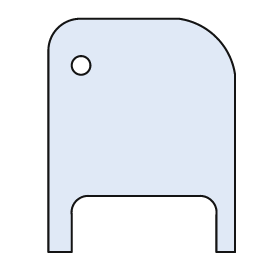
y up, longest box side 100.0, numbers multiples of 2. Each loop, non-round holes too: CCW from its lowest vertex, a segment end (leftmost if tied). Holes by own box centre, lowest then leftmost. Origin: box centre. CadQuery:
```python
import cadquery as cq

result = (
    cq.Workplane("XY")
    .moveTo(-40.0, -50.0)
    .lineTo(-30.0, -50.0)
    .lineTo(-30.0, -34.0)
    .threePointArc((-28.0, -28.0), (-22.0, -26.0))
    .lineTo(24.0, -26.0)
    .threePointArc((30.0, -28.0), (32.0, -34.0))
    .lineTo(32.0, -50.0)
    .lineTo(40.0, -50.0)
    .lineTo(40.0, 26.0)
    .threePointArc((32.0, 42.0), (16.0, 50.0))
    .lineTo(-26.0, 50.0)
    .threePointArc((-36.0, 46.0), (-40.0, 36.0))
    .close()
    .moveTo(-26.0, 30.0)
    .circle(4.0)
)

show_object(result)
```